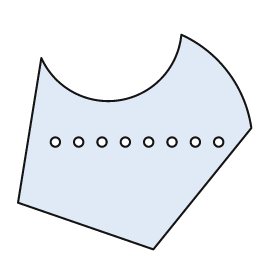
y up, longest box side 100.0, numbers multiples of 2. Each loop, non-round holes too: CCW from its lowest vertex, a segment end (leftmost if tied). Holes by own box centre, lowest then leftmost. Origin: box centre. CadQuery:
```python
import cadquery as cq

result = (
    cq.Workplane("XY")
    .moveTo(8.0, -46.0)
    .lineTo(50.0, 6.0)
    .threePointArc((40.0, 30.0), (20.0, 46.0))
    .threePointArc((-6.0, 18.0), (-40.0, 36.0))
    .lineTo(-50.0, -26.0)
    .close()
    .moveTo(-34.0, 0.0)
    .circle(2.0)
    .moveTo(-24.0, 0.0)
    .circle(2.0)
    .moveTo(-14.0, 0.0)
    .circle(2.0)
    .moveTo(-4.0, 0.0)
    .circle(2.0)
    .moveTo(6.0, 0.0)
    .circle(2.0)
    .moveTo(16.0, 0.0)
    .circle(2.0)
    .moveTo(26.0, 0.0)
    .circle(2.0)
    .moveTo(36.0, 0.0)
    .circle(2.0)
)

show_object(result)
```